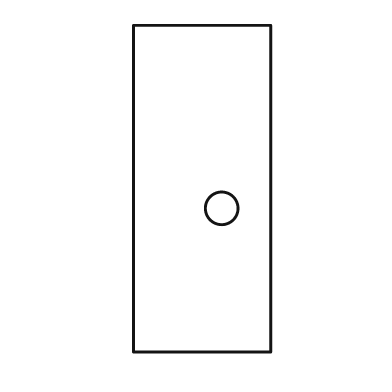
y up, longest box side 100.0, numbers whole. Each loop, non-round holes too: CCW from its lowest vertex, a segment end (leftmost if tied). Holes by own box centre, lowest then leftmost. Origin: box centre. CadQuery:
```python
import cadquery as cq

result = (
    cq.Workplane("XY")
    .moveTo(-21.0, -50.0)
    .lineTo(21.0, -50.0)
    .lineTo(21.0, 50.0)
    .lineTo(-21.0, 50.0)
    .close()
    .moveTo(6.0, -6.0)
    .circle(5.0)
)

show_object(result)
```